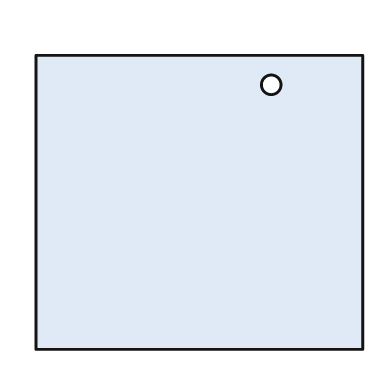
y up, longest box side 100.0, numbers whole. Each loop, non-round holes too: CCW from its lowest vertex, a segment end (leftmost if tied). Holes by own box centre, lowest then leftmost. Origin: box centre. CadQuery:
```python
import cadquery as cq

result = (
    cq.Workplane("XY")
    .moveTo(-50.0, -45.0)
    .lineTo(50.0, -45.0)
    .lineTo(50.0, 45.0)
    .lineTo(-50.0, 45.0)
    .close()
    .moveTo(22.0, 36.0)
    .circle(3.0)
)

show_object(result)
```